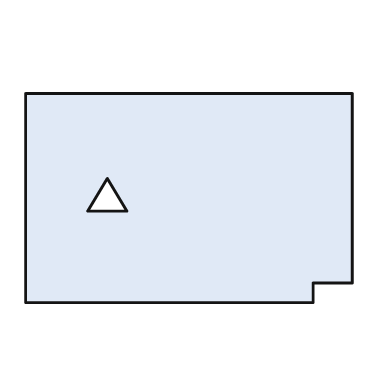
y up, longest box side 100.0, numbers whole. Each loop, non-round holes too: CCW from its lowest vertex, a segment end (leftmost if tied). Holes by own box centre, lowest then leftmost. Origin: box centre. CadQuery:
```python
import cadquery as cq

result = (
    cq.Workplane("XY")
    .moveTo(-50.0, -32.0)
    .lineTo(38.0, -32.0)
    .lineTo(38.0, -26.0)
    .lineTo(50.0, -26.0)
    .lineTo(50.0, 32.0)
    .lineTo(-50.0, 32.0)
    .close()
    .moveTo(-31.0, -4.0)
    .lineTo(-19.0, -4.0)
    .lineTo(-25.0, 6.0)
    .close()
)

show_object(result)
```